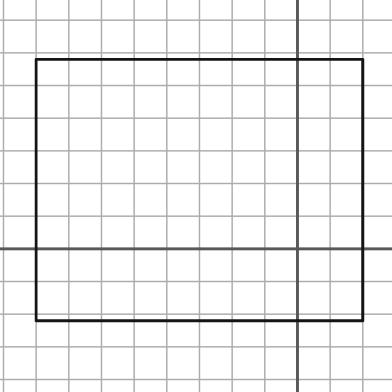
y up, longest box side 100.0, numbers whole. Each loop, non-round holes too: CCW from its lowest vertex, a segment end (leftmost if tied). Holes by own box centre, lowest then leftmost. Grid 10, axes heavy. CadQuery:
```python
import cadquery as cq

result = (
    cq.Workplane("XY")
    .moveTo(-80.0, -22.0)
    .lineTo(20.0, -22.0)
    .lineTo(20.0, 58.0)
    .lineTo(-80.0, 58.0)
    .close()
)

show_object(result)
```